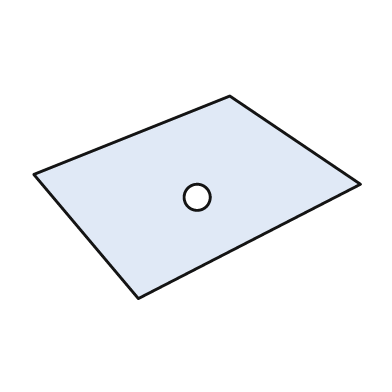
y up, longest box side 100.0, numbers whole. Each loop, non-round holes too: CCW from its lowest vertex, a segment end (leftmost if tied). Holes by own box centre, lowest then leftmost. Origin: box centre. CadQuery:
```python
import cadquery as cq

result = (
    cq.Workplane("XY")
    .moveTo(-18.0, -31.0)
    .lineTo(50.0, 4.0)
    .lineTo(10.0, 31.0)
    .lineTo(-50.0, 7.0)
    .close()
    .moveTo(0.0, 0.0)
    .circle(4.0)
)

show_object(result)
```